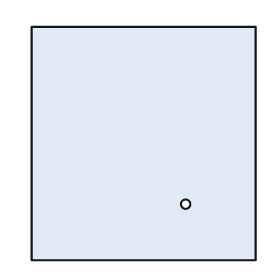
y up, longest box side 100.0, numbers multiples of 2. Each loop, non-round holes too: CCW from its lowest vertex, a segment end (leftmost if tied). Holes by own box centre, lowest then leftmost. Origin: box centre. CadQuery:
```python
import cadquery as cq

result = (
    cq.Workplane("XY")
    .moveTo(-48.0, -50.0)
    .lineTo(48.0, -50.0)
    .lineTo(48.0, 50.0)
    .lineTo(-48.0, 50.0)
    .close()
    .moveTo(18.0, -26.0)
    .circle(2.0)
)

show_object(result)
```